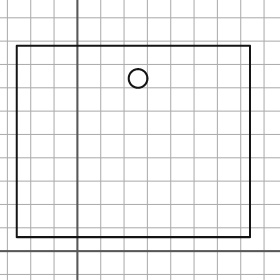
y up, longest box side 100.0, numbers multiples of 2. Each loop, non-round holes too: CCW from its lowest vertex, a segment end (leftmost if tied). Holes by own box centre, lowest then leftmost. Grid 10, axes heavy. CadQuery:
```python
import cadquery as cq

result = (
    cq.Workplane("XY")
    .moveTo(-26.0, 6.0)
    .lineTo(74.0, 6.0)
    .lineTo(74.0, 88.0)
    .lineTo(-26.0, 88.0)
    .close()
    .moveTo(26.0, 74.0)
    .circle(4.0)
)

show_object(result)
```